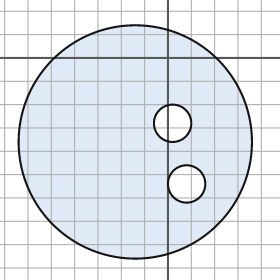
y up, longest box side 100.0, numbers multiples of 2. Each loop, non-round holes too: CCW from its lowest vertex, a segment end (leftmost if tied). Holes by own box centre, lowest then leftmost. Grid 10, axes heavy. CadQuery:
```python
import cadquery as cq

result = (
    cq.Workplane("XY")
    .moveTo(-14.0, -36.0)
    .circle(50.0)
    .moveTo(8.0, -54.0)
    .circle(8.0)
    .moveTo(2.0, -28.0)
    .circle(8.0)
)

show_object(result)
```